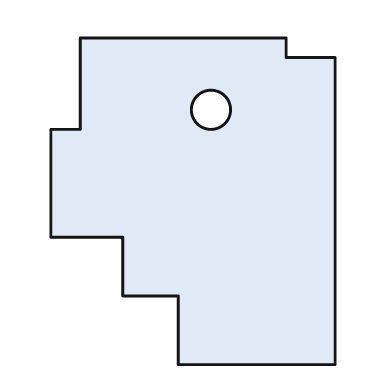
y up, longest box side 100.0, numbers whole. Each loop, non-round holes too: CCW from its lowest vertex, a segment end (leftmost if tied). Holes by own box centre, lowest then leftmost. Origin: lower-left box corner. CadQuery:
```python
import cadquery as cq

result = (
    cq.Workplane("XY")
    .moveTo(39.0, 0.0)
    .lineTo(87.0, 0.0)
    .lineTo(87.0, 94.0)
    .lineTo(72.0, 94.0)
    .lineTo(72.0, 100.0)
    .lineTo(9.0, 100.0)
    .lineTo(9.0, 72.0)
    .lineTo(0.0, 72.0)
    .lineTo(0.0, 39.0)
    .lineTo(22.0, 39.0)
    .lineTo(22.0, 21.0)
    .lineTo(39.0, 21.0)
    .close()
    .moveTo(49.0, 78.0)
    .circle(6.0)
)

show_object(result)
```